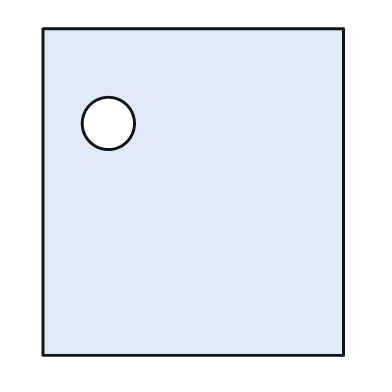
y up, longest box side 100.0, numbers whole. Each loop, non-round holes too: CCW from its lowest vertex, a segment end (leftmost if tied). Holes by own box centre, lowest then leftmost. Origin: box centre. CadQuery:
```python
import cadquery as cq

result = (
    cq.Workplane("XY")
    .moveTo(-46.0, -50.0)
    .lineTo(46.0, -50.0)
    .lineTo(46.0, 50.0)
    .lineTo(-46.0, 50.0)
    .close()
    .moveTo(-26.0, 21.0)
    .circle(8.0)
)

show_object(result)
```